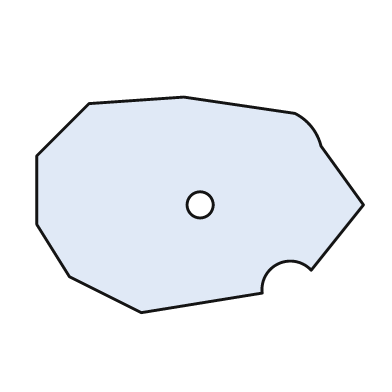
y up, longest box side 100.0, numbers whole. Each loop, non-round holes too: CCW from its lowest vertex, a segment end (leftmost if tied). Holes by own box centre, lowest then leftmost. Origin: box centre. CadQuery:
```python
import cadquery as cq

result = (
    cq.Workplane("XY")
    .moveTo(-18.0, -33.0)
    .lineTo(19.0, -27.0)
    .threePointArc((24.0, -18.0), (34.0, -20.0))
    .lineTo(50.0, 0.0)
    .lineTo(37.0, 18.0)
    .threePointArc((34.0, 24.0), (29.0, 28.0))
    .lineTo(-5.0, 33.0)
    .lineTo(-34.0, 31.0)
    .lineTo(-50.0, 15.0)
    .lineTo(-50.0, -6.0)
    .lineTo(-40.0, -22.0)
    .close()
    .moveTo(0.0, 0.0)
    .circle(4.0)
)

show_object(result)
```